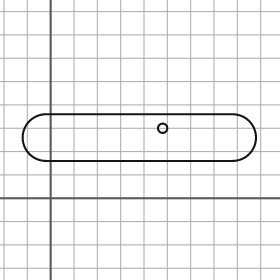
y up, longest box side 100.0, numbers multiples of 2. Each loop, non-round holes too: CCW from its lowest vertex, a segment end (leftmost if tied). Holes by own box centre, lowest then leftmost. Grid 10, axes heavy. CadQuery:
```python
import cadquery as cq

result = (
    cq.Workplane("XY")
    .moveTo(-2.0, 16.0)
    .lineTo(78.0, 16.0)
    .threePointArc((88.0, 26.0), (78.0, 36.0))
    .lineTo(-2.0, 36.0)
    .threePointArc((-12.0, 26.0), (-2.0, 16.0))
    .close()
    .moveTo(48.0, 30.0)
    .circle(2.0)
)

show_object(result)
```